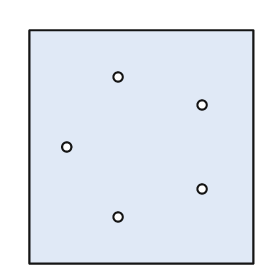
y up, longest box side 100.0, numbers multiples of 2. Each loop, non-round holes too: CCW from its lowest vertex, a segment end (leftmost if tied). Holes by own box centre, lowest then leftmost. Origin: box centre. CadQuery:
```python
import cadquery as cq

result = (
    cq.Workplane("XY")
    .moveTo(-48.0, -50.0)
    .lineTo(48.0, -50.0)
    .lineTo(48.0, 50.0)
    .lineTo(-48.0, 50.0)
    .close()
    .moveTo(-10.0, -30.0)
    .circle(2.0)
    .moveTo(26.0, -18.0)
    .circle(2.0)
    .moveTo(-32.0, 0.0)
    .circle(2.0)
    .moveTo(26.0, 18.0)
    .circle(2.0)
    .moveTo(-10.0, 30.0)
    .circle(2.0)
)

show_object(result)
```